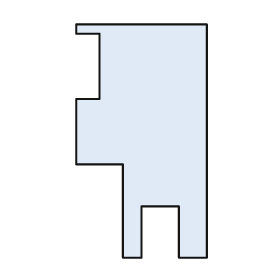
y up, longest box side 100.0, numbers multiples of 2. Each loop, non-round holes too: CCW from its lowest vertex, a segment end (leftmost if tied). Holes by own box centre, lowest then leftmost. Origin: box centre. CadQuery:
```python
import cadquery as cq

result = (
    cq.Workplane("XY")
    .moveTo(-8.0, -50.0)
    .lineTo(0.0, -50.0)
    .lineTo(0.0, -28.0)
    .lineTo(16.0, -28.0)
    .lineTo(16.0, -50.0)
    .lineTo(28.0, -50.0)
    .lineTo(28.0, 50.0)
    .lineTo(-28.0, 50.0)
    .lineTo(-28.0, 46.0)
    .lineTo(-18.0, 46.0)
    .lineTo(-18.0, 18.0)
    .lineTo(-28.0, 18.0)
    .lineTo(-28.0, -10.0)
    .lineTo(-8.0, -10.0)
    .close()
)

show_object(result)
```